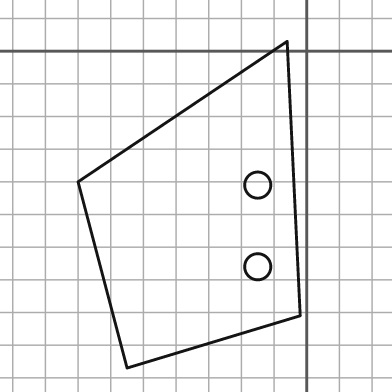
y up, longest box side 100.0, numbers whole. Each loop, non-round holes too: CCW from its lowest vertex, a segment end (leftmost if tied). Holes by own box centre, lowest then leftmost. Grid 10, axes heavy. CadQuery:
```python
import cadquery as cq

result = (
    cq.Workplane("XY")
    .moveTo(-55.0, -97.0)
    .lineTo(-2.0, -81.0)
    .lineTo(-6.0, 3.0)
    .lineTo(-70.0, -40.0)
    .close()
    .moveTo(-15.0, -66.0)
    .circle(4.0)
    .moveTo(-15.0, -41.0)
    .circle(4.0)
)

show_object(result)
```